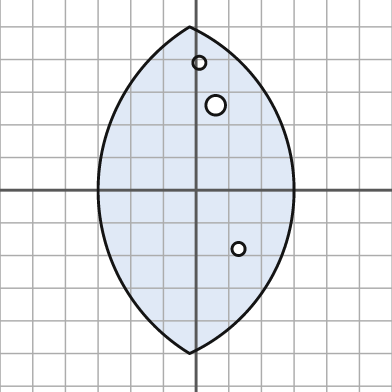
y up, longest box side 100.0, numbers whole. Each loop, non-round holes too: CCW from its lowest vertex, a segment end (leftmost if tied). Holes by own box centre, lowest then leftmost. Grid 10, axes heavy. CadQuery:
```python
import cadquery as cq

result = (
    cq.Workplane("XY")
    .moveTo(-2.0, -50.0)
    .threePointArc((30.0, 0.0), (-2.0, 50.0))
    .threePointArc((-30.0, 0.0), (-2.0, -50.0))
    .close()
    .moveTo(13.0, -18.0)
    .circle(2.0)
    .moveTo(6.0, 26.0)
    .circle(3.0)
    .moveTo(1.0, 39.0)
    .circle(2.0)
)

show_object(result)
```